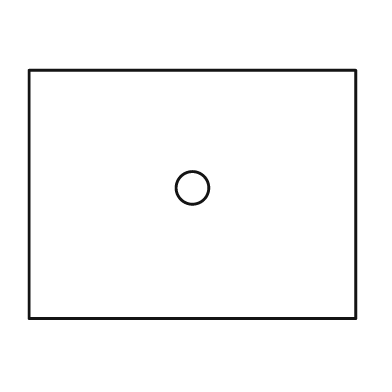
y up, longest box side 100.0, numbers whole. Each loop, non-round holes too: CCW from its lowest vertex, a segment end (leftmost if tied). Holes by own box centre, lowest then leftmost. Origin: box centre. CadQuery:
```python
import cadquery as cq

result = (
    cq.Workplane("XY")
    .moveTo(-50.0, -38.0)
    .lineTo(50.0, -38.0)
    .lineTo(50.0, 38.0)
    .lineTo(-50.0, 38.0)
    .close()
    .moveTo(0.0, 2.0)
    .circle(5.0)
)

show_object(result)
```